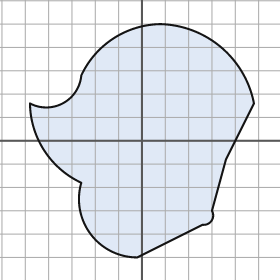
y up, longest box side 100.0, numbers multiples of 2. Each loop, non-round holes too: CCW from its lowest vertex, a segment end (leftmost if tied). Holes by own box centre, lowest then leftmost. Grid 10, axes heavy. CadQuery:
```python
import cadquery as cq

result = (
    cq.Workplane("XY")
    .moveTo(-2.0, -50.0)
    .lineTo(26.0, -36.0)
    .threePointArc((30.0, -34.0), (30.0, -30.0))
    .lineTo(36.0, -8.0)
    .lineTo(48.0, 16.0)
    .threePointArc((34.0, 40.0), (8.0, 50.0))
    .threePointArc((-12.0, 44.0), (-26.0, 28.0))
    .threePointArc((-34.0, 16.0), (-48.0, 16.0))
    .threePointArc((-42.0, -4.0), (-26.0, -18.0))
    .threePointArc((-22.0, -40.0), (-2.0, -50.0))
    .close()
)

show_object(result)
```